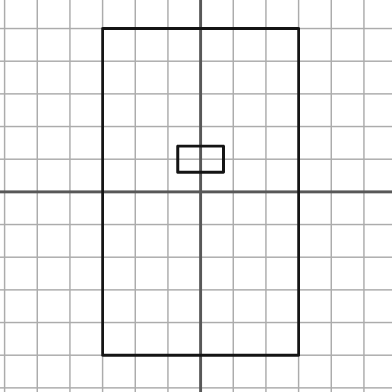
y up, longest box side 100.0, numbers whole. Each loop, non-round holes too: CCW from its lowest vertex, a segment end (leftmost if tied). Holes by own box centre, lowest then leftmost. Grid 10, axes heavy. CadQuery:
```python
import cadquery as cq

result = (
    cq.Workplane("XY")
    .moveTo(-30.0, -50.0)
    .lineTo(30.0, -50.0)
    .lineTo(30.0, 50.0)
    .lineTo(-30.0, 50.0)
    .close()
    .moveTo(-7.0, 6.0)
    .lineTo(7.0, 6.0)
    .lineTo(7.0, 14.0)
    .lineTo(-7.0, 14.0)
    .close()
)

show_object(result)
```